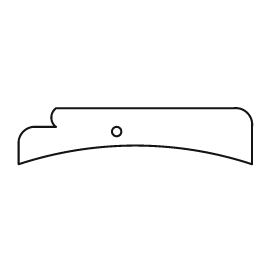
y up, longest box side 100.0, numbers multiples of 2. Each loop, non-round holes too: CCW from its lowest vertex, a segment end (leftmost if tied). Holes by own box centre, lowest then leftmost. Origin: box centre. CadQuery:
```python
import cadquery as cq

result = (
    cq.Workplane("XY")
    .moveTo(-50.0, -12.0)
    .threePointArc((0.0, -4.0), (50.0, -12.0))
    .lineTo(50.0, 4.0)
    .threePointArc((48.0, 10.0), (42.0, 12.0))
    .lineTo(-34.0, 12.0)
    .threePointArc((-36.0, 8.0), (-34.0, 4.0))
    .lineTo(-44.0, 4.0)
    .threePointArc((-48.0, 2.0), (-50.0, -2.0))
    .close()
    .moveTo(-8.0, 2.0)
    .circle(2.0)
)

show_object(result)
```